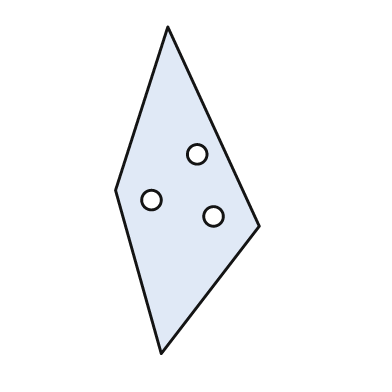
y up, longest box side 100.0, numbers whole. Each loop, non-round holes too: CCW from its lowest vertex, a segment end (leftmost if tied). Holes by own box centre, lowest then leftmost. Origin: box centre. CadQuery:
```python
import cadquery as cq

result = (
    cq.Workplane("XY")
    .moveTo(-8.0, -50.0)
    .lineTo(22.0, -11.0)
    .lineTo(-6.0, 50.0)
    .lineTo(-22.0, 0.0)
    .close()
    .moveTo(8.0, -8.0)
    .circle(3.0)
    .moveTo(-11.0, -3.0)
    .circle(3.0)
    .moveTo(3.0, 11.0)
    .circle(3.0)
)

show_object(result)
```